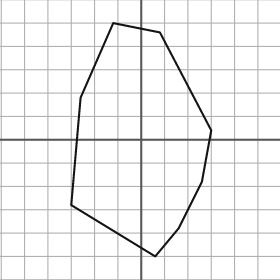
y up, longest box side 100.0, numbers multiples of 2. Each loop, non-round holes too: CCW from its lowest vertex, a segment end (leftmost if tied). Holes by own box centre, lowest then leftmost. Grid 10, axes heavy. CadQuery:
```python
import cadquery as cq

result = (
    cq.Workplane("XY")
    .moveTo(6.0, -50.0)
    .lineTo(16.0, -38.0)
    .lineTo(26.0, -18.0)
    .lineTo(30.0, 4.0)
    .lineTo(8.0, 46.0)
    .lineTo(-12.0, 50.0)
    .lineTo(-26.0, 18.0)
    .lineTo(-30.0, -28.0)
    .close()
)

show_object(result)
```